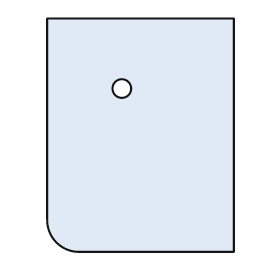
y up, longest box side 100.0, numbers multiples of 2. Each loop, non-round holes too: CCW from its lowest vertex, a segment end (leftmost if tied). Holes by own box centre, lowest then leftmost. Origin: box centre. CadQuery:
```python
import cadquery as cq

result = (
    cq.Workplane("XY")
    .moveTo(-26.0, -50.0)
    .lineTo(40.0, -50.0)
    .lineTo(40.0, 50.0)
    .lineTo(-40.0, 50.0)
    .lineTo(-40.0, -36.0)
    .threePointArc((-36.0, -46.0), (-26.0, -50.0))
    .close()
    .moveTo(-8.0, 20.0)
    .circle(4.0)
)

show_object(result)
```